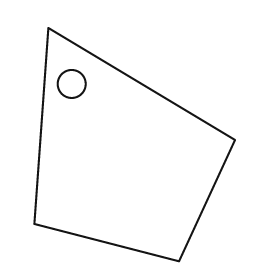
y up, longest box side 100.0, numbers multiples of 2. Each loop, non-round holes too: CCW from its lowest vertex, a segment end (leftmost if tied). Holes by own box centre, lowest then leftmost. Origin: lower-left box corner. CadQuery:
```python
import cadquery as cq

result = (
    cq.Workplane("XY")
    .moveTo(62.0, 0.0)
    .lineTo(86.0, 52.0)
    .lineTo(6.0, 100.0)
    .lineTo(0.0, 16.0)
    .close()
    .moveTo(16.0, 76.0)
    .circle(6.0)
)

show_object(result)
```